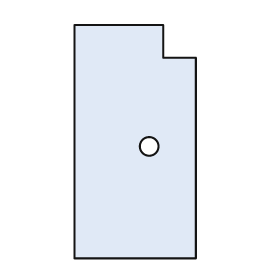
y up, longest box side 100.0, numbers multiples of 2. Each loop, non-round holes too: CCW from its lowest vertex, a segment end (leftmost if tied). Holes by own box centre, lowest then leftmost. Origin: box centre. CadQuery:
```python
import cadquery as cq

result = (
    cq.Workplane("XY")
    .moveTo(-26.0, -50.0)
    .lineTo(26.0, -50.0)
    .lineTo(26.0, 36.0)
    .lineTo(12.0, 36.0)
    .lineTo(12.0, 50.0)
    .lineTo(-26.0, 50.0)
    .close()
    .moveTo(6.0, -2.0)
    .circle(4.0)
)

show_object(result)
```